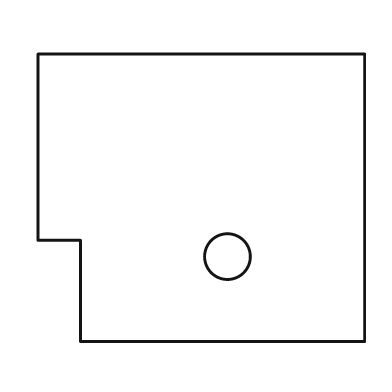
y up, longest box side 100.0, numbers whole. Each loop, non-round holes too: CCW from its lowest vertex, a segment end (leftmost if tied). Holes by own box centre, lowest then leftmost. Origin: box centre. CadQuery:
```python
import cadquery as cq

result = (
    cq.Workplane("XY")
    .moveTo(-37.0, -44.0)
    .lineTo(50.0, -44.0)
    .lineTo(50.0, 44.0)
    .lineTo(-50.0, 44.0)
    .lineTo(-50.0, -13.0)
    .lineTo(-37.0, -13.0)
    .close()
    .moveTo(8.0, -18.0)
    .circle(7.0)
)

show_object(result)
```